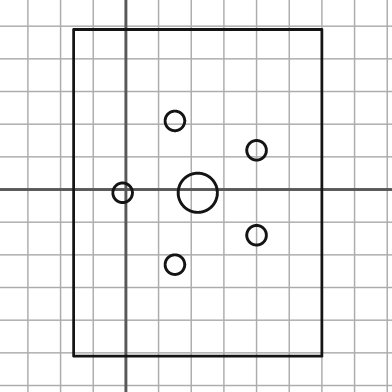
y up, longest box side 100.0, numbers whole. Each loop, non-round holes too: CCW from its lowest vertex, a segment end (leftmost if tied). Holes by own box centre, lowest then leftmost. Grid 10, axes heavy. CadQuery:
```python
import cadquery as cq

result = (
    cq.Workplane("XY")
    .moveTo(-16.0, -51.0)
    .lineTo(60.0, -51.0)
    .lineTo(60.0, 49.0)
    .lineTo(-16.0, 49.0)
    .close()
    .moveTo(15.0, -23.0)
    .circle(3.0)
    .moveTo(40.0, -14.0)
    .circle(3.0)
    .moveTo(-1.0, -1.0)
    .circle(3.0)
    .moveTo(22.0, -1.0)
    .circle(6.0)
    .moveTo(40.0, 12.0)
    .circle(3.0)
    .moveTo(15.0, 21.0)
    .circle(3.0)
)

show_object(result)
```